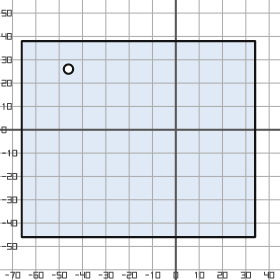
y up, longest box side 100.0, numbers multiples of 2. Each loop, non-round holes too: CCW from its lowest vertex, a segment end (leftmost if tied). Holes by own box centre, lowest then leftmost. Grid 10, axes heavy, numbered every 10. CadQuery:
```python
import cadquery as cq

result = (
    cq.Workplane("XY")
    .moveTo(-66.0, -46.0)
    .lineTo(34.0, -46.0)
    .lineTo(34.0, 38.0)
    .lineTo(-66.0, 38.0)
    .close()
    .moveTo(-46.0, 26.0)
    .circle(2.0)
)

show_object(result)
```